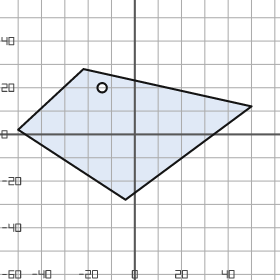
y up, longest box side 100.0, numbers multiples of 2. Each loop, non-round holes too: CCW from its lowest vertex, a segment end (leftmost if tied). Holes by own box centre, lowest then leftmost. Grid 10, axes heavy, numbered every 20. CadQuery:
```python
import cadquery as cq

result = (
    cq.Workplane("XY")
    .moveTo(-4.0, -28.0)
    .lineTo(50.0, 12.0)
    .lineTo(-22.0, 28.0)
    .lineTo(-50.0, 2.0)
    .close()
    .moveTo(-14.0, 20.0)
    .circle(2.0)
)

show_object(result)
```